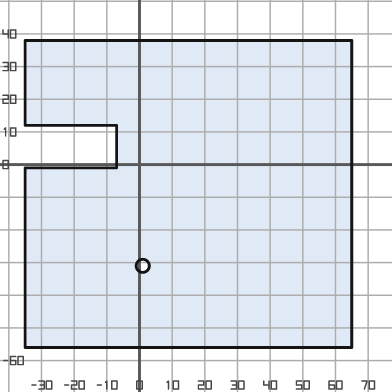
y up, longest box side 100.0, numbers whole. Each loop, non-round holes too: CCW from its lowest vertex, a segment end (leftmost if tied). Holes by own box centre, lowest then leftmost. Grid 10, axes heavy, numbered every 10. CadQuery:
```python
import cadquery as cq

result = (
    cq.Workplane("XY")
    .moveTo(-35.0, -56.0)
    .lineTo(65.0, -56.0)
    .lineTo(65.0, 38.0)
    .lineTo(-35.0, 38.0)
    .lineTo(-35.0, 12.0)
    .lineTo(-7.0, 12.0)
    .lineTo(-7.0, -1.0)
    .lineTo(-35.0, -1.0)
    .close()
    .moveTo(1.0, -31.0)
    .circle(2.0)
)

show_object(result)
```